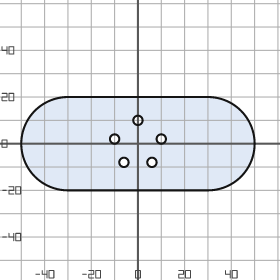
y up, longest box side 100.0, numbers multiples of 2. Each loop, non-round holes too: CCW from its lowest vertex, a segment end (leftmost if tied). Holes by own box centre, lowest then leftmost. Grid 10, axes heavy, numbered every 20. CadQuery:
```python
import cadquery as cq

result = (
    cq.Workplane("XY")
    .moveTo(-30.0, -20.0)
    .lineTo(30.0, -20.0)
    .threePointArc((50.0, 0.0), (30.0, 20.0))
    .lineTo(-30.0, 20.0)
    .threePointArc((-50.0, 0.0), (-30.0, -20.0))
    .close()
    .moveTo(-6.0, -8.0)
    .circle(2.0)
    .moveTo(6.0, -8.0)
    .circle(2.0)
    .moveTo(-10.0, 2.0)
    .circle(2.0)
    .moveTo(10.0, 2.0)
    .circle(2.0)
    .moveTo(0.0, 10.0)
    .circle(2.0)
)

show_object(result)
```